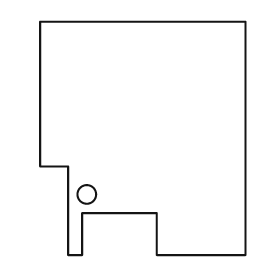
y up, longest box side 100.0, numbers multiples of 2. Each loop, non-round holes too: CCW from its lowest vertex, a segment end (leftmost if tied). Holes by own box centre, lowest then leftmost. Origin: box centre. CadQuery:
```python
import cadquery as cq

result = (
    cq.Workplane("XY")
    .moveTo(-32.0, -50.0)
    .lineTo(-26.0, -50.0)
    .lineTo(-26.0, -32.0)
    .lineTo(6.0, -32.0)
    .lineTo(6.0, -50.0)
    .lineTo(44.0, -50.0)
    .lineTo(44.0, 50.0)
    .lineTo(-44.0, 50.0)
    .lineTo(-44.0, -12.0)
    .lineTo(-32.0, -12.0)
    .close()
    .moveTo(-24.0, -24.0)
    .circle(4.0)
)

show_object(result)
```